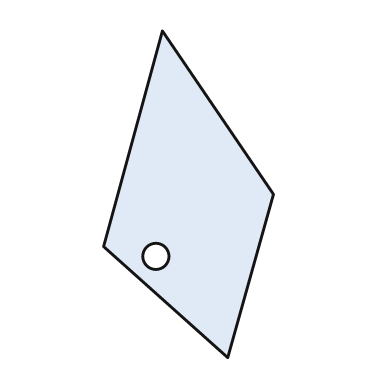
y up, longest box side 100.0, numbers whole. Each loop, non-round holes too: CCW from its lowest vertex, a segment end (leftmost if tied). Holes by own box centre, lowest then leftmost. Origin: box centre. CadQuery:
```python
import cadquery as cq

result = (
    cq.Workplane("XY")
    .moveTo(12.0, -50.0)
    .lineTo(26.0, 0.0)
    .lineTo(-8.0, 50.0)
    .lineTo(-26.0, -16.0)
    .close()
    .moveTo(-10.0, -19.0)
    .circle(4.0)
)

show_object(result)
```